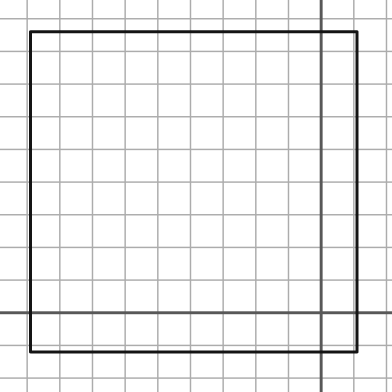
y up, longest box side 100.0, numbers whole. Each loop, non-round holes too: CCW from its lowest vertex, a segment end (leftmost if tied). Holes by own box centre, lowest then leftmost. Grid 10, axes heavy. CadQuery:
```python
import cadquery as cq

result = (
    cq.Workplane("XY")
    .moveTo(-89.0, -12.0)
    .lineTo(11.0, -12.0)
    .lineTo(11.0, 86.0)
    .lineTo(-89.0, 86.0)
    .close()
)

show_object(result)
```